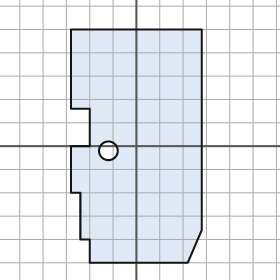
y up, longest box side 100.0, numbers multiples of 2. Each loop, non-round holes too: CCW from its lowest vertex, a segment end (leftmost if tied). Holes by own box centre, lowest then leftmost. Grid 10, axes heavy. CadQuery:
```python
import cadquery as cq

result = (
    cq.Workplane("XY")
    .moveTo(-20.0, -50.0)
    .lineTo(22.0, -50.0)
    .lineTo(28.0, -36.0)
    .lineTo(28.0, 50.0)
    .lineTo(-28.0, 50.0)
    .lineTo(-28.0, 16.0)
    .lineTo(-20.0, 16.0)
    .lineTo(-20.0, 0.0)
    .lineTo(-28.0, 0.0)
    .lineTo(-28.0, -20.0)
    .lineTo(-24.0, -20.0)
    .lineTo(-24.0, -40.0)
    .lineTo(-20.0, -40.0)
    .close()
    .moveTo(-12.0, -2.0)
    .circle(4.0)
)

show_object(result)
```